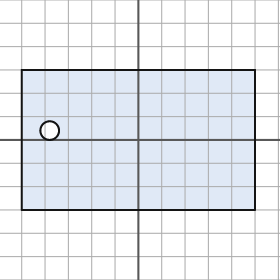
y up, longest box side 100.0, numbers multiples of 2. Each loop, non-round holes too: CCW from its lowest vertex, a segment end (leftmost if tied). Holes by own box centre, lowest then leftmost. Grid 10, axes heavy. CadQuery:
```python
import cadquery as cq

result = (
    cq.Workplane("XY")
    .moveTo(-50.0, -30.0)
    .lineTo(50.0, -30.0)
    .lineTo(50.0, 30.0)
    .lineTo(-50.0, 30.0)
    .close()
    .moveTo(-38.0, 4.0)
    .circle(4.0)
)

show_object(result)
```